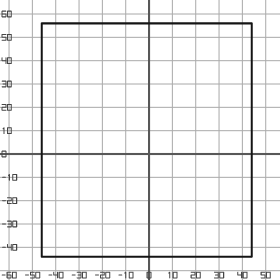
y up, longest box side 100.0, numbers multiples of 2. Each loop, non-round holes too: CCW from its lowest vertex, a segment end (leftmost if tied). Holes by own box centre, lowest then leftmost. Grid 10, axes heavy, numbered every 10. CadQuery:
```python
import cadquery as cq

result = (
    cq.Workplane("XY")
    .moveTo(-46.0, -44.0)
    .lineTo(44.0, -44.0)
    .lineTo(44.0, 56.0)
    .lineTo(-46.0, 56.0)
    .close()
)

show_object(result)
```